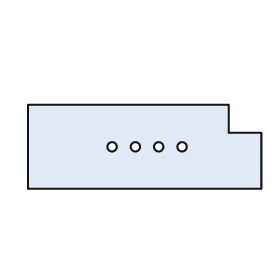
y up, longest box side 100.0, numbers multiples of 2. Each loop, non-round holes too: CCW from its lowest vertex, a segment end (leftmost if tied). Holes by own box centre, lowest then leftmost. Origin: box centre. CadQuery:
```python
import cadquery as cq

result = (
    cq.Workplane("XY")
    .moveTo(-50.0, -18.0)
    .lineTo(50.0, -18.0)
    .lineTo(50.0, 6.0)
    .lineTo(36.0, 6.0)
    .lineTo(36.0, 18.0)
    .lineTo(-50.0, 18.0)
    .close()
    .moveTo(-14.0, 0.0)
    .circle(2.0)
    .moveTo(-4.0, 0.0)
    .circle(2.0)
    .moveTo(6.0, 0.0)
    .circle(2.0)
    .moveTo(16.0, 0.0)
    .circle(2.0)
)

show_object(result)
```